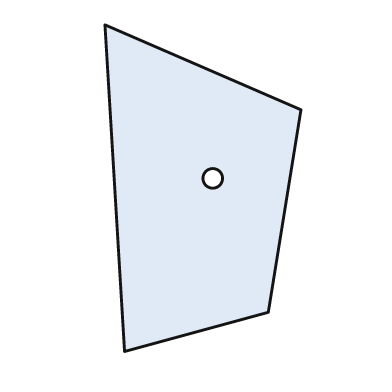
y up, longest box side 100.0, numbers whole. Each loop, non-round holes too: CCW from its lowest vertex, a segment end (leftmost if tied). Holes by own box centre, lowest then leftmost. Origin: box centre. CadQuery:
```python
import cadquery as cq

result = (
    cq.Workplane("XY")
    .moveTo(-24.0, -50.0)
    .lineTo(20.0, -38.0)
    .lineTo(30.0, 24.0)
    .lineTo(-30.0, 50.0)
    .close()
    .moveTo(3.0, 3.0)
    .circle(3.0)
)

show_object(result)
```